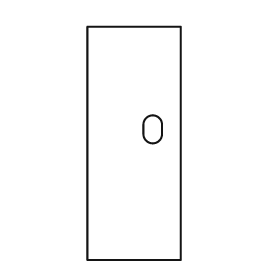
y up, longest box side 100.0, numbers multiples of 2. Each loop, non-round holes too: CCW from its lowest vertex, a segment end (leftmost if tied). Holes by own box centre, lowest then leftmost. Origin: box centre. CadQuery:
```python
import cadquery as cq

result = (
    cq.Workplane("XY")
    .moveTo(-20.0, -50.0)
    .lineTo(20.0, -50.0)
    .lineTo(20.0, 50.0)
    .lineTo(-20.0, 50.0)
    .close()
    .moveTo(4.0, 4.0)
    .threePointArc((8.0, 0.0), (12.0, 4.0))
    .lineTo(12.0, 8.0)
    .threePointArc((8.0, 12.0), (4.0, 8.0))
    .close()
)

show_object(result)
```